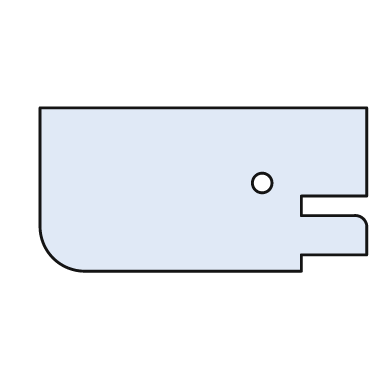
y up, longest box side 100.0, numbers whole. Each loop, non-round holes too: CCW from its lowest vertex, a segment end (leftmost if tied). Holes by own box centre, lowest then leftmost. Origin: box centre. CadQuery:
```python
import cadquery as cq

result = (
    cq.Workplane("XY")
    .moveTo(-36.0, -25.0)
    .lineTo(30.0, -25.0)
    .lineTo(30.0, -20.0)
    .lineTo(50.0, -20.0)
    .lineTo(50.0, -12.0)
    .threePointArc((49.0, -9.0), (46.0, -8.0))
    .lineTo(30.0, -8.0)
    .lineTo(30.0, -2.0)
    .lineTo(50.0, -2.0)
    .lineTo(50.0, 25.0)
    .lineTo(-50.0, 25.0)
    .lineTo(-50.0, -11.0)
    .threePointArc((-46.0, -21.0), (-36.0, -25.0))
    .close()
    .moveTo(18.0, 2.0)
    .circle(3.0)
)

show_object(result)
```